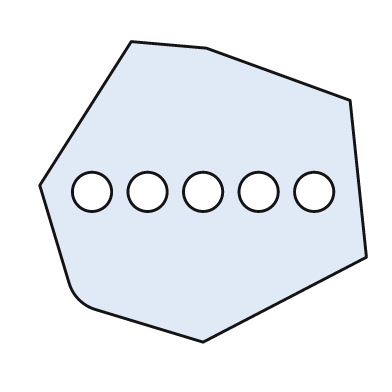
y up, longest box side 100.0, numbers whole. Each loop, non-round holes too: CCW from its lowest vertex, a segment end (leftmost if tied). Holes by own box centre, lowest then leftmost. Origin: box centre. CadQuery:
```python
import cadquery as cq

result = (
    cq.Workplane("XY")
    .moveTo(0.0, -46.0)
    .lineTo(50.0, -20.0)
    .lineTo(45.0, 28.0)
    .lineTo(1.0, 44.0)
    .lineTo(-22.0, 46.0)
    .lineTo(-50.0, 2.0)
    .lineTo(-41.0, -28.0)
    .threePointArc((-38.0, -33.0), (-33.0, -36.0))
    .close()
    .moveTo(-34.0, 0.0)
    .circle(6.0)
    .moveTo(-17.0, 0.0)
    .circle(6.0)
    .moveTo(0.0, 0.0)
    .circle(6.0)
    .moveTo(17.0, 0.0)
    .circle(6.0)
    .moveTo(34.0, 0.0)
    .circle(6.0)
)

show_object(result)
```